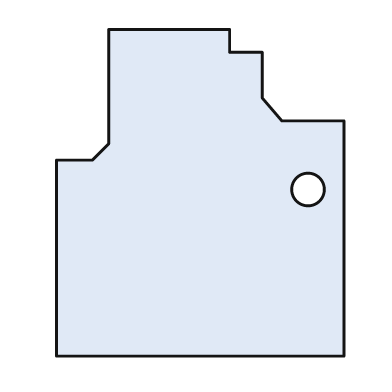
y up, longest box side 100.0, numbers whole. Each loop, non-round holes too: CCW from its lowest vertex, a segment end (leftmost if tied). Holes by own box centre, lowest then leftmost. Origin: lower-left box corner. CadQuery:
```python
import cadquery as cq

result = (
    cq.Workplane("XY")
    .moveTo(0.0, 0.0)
    .lineTo(88.0, 0.0)
    .lineTo(88.0, 72.0)
    .lineTo(69.0, 72.0)
    .lineTo(63.0, 79.0)
    .lineTo(63.0, 93.0)
    .lineTo(53.0, 93.0)
    .lineTo(53.0, 100.0)
    .lineTo(16.0, 100.0)
    .lineTo(16.0, 65.0)
    .lineTo(11.0, 60.0)
    .lineTo(0.0, 60.0)
    .close()
    .moveTo(77.0, 51.0)
    .circle(5.0)
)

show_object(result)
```